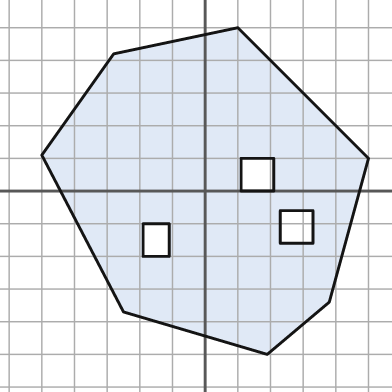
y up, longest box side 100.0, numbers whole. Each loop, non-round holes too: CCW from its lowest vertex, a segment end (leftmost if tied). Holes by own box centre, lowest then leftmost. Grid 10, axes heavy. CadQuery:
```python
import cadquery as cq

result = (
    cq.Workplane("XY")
    .moveTo(19.0, -50.0)
    .lineTo(38.0, -34.0)
    .lineTo(50.0, 10.0)
    .lineTo(10.0, 50.0)
    .lineTo(-28.0, 42.0)
    .lineTo(-50.0, 11.0)
    .lineTo(-25.0, -37.0)
    .close()
    .moveTo(-19.0, -20.0)
    .lineTo(-11.0, -20.0)
    .lineTo(-11.0, -10.0)
    .lineTo(-19.0, -10.0)
    .close()
    .moveTo(23.0, -16.0)
    .lineTo(33.0, -16.0)
    .lineTo(33.0, -6.0)
    .lineTo(23.0, -6.0)
    .close()
    .moveTo(11.0, 0.0)
    .lineTo(21.0, 0.0)
    .lineTo(21.0, 10.0)
    .lineTo(11.0, 10.0)
    .close()
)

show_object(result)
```